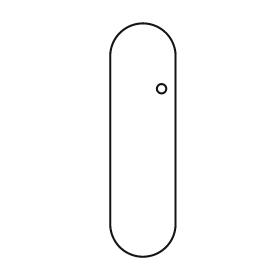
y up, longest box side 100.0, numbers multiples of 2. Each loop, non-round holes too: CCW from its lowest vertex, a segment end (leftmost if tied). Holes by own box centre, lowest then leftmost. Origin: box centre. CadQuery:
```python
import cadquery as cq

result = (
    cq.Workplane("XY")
    .moveTo(-14.0, -36.0)
    .threePointArc((0.0, -50.0), (14.0, -36.0))
    .lineTo(14.0, 36.0)
    .threePointArc((0.0, 50.0), (-14.0, 36.0))
    .close()
    .moveTo(8.0, 22.0)
    .circle(2.0)
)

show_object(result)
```